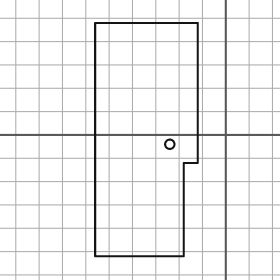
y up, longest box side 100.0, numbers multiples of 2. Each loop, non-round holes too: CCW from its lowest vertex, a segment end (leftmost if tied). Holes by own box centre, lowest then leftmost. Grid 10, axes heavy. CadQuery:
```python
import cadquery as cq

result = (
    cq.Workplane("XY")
    .moveTo(-56.0, -52.0)
    .lineTo(-18.0, -52.0)
    .lineTo(-18.0, -12.0)
    .lineTo(-12.0, -12.0)
    .lineTo(-12.0, 48.0)
    .lineTo(-56.0, 48.0)
    .close()
    .moveTo(-24.0, -4.0)
    .circle(2.0)
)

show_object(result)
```